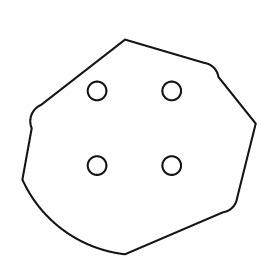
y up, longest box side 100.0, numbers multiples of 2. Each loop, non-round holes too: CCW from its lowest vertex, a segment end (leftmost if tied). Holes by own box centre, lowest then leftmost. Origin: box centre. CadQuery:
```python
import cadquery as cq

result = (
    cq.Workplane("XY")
    .moveTo(-6.0, -46.0)
    .lineTo(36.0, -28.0)
    .threePointArc((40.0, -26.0), (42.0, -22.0))
    .lineTo(50.0, 10.0)
    .lineTo(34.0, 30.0)
    .threePointArc((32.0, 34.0), (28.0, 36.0))
    .lineTo(-6.0, 46.0)
    .lineTo(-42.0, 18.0)
    .threePointArc((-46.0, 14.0), (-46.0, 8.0))
    .lineTo(-50.0, -14.0)
    .threePointArc((-32.0, -36.0), (-6.0, -46.0))
    .close()
    .moveTo(-18.0, -8.0)
    .circle(4.0)
    .moveTo(14.0, -8.0)
    .circle(4.0)
    .moveTo(-18.0, 24.0)
    .circle(4.0)
    .moveTo(14.0, 24.0)
    .circle(4.0)
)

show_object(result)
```